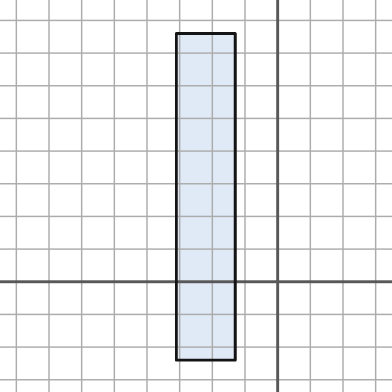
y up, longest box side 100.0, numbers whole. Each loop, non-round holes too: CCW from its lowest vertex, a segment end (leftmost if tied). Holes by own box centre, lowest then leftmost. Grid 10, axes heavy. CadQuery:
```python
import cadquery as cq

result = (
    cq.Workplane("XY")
    .moveTo(-31.0, -24.0)
    .lineTo(-13.0, -24.0)
    .lineTo(-13.0, 76.0)
    .lineTo(-31.0, 76.0)
    .close()
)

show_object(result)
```